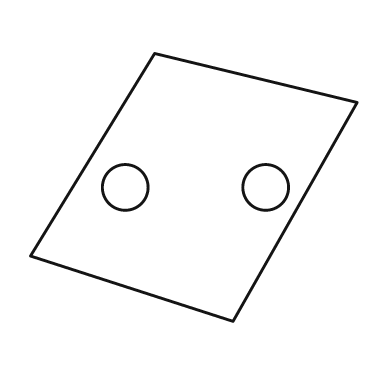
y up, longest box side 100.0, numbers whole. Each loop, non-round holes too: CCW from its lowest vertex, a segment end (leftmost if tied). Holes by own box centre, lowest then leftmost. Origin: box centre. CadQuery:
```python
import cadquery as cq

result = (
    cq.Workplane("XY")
    .moveTo(12.0, -41.0)
    .lineTo(50.0, 26.0)
    .lineTo(-12.0, 41.0)
    .lineTo(-50.0, -21.0)
    .close()
    .moveTo(-21.0, 0.0)
    .circle(7.0)
    .moveTo(22.0, 0.0)
    .circle(7.0)
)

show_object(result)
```